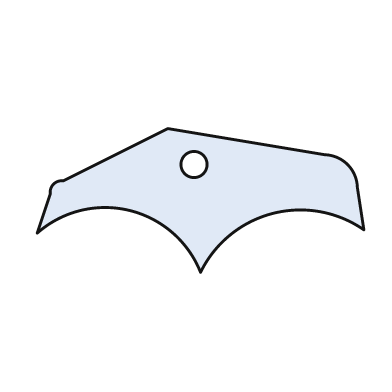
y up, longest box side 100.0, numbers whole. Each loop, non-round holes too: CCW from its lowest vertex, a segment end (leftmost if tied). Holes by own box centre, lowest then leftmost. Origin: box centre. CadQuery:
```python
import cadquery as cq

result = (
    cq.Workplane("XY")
    .moveTo(0.0, -22.0)
    .threePointArc((22.0, -4.0), (50.0, -9.0))
    .lineTo(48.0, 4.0)
    .threePointArc((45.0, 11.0), (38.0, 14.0))
    .lineTo(-10.0, 22.0)
    .lineTo(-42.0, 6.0)
    .threePointArc((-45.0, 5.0), (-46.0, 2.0))
    .lineTo(-50.0, -10.0)
    .threePointArc((-22.0, -3.0), (0.0, -22.0))
    .close()
    .moveTo(-2.0, 11.0)
    .circle(4.0)
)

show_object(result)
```